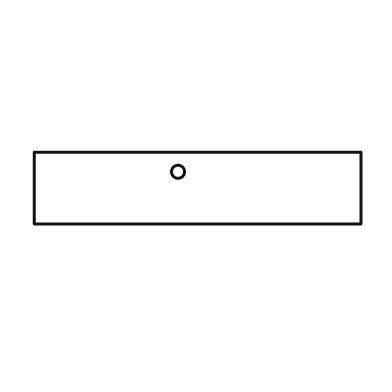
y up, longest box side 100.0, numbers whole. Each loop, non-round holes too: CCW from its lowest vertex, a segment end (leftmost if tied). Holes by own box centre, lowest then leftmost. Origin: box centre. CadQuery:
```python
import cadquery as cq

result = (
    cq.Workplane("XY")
    .moveTo(-50.0, -11.0)
    .lineTo(50.0, -11.0)
    .lineTo(50.0, 11.0)
    .lineTo(-50.0, 11.0)
    .close()
    .moveTo(-6.0, 5.0)
    .circle(2.0)
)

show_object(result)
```